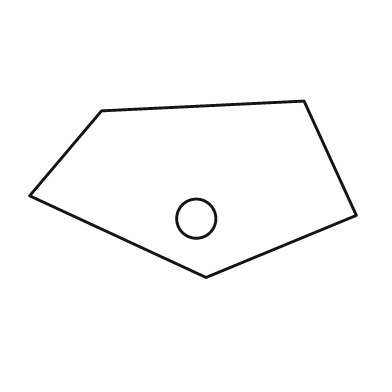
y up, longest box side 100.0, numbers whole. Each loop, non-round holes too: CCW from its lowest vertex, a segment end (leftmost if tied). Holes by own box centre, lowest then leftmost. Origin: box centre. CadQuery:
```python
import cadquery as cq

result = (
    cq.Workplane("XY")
    .moveTo(4.0, -27.0)
    .lineTo(50.0, -8.0)
    .lineTo(34.0, 27.0)
    .lineTo(-28.0, 24.0)
    .lineTo(-50.0, -2.0)
    .close()
    .moveTo(1.0, -9.0)
    .circle(6.0)
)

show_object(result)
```